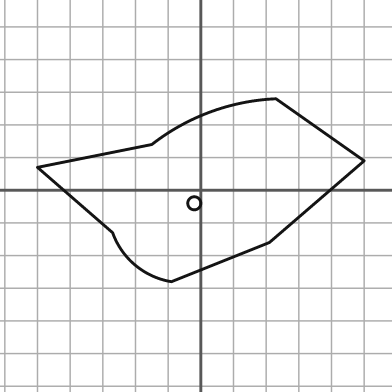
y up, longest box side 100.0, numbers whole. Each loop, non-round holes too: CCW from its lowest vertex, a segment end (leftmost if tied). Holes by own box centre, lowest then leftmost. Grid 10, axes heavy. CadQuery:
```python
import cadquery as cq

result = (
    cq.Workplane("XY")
    .moveTo(-9.0, -28.0)
    .lineTo(21.0, -16.0)
    .lineTo(50.0, 9.0)
    .lineTo(23.0, 28.0)
    .threePointArc((3.0, 24.0), (-15.0, 14.0))
    .lineTo(-50.0, 7.0)
    .lineTo(-27.0, -13.0)
    .threePointArc((-20.0, -23.0), (-9.0, -28.0))
    .close()
    .moveTo(-2.0, -4.0)
    .circle(2.0)
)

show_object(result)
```